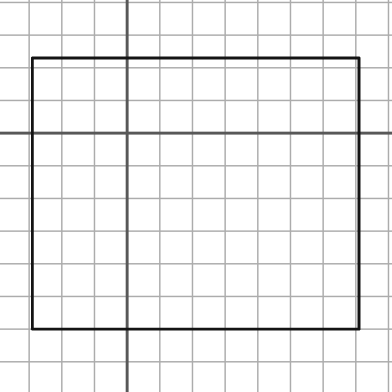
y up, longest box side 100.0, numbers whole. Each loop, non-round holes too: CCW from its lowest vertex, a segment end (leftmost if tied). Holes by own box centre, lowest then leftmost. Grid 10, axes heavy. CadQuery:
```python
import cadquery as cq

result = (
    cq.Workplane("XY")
    .moveTo(-29.0, -60.0)
    .lineTo(71.0, -60.0)
    .lineTo(71.0, 23.0)
    .lineTo(-29.0, 23.0)
    .close()
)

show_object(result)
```